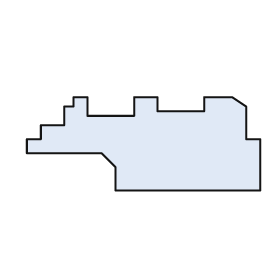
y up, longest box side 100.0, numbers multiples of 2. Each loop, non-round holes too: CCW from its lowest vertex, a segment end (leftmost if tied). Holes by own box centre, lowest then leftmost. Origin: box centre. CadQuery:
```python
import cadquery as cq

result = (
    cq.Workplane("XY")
    .moveTo(-12.0, -20.0)
    .lineTo(50.0, -20.0)
    .lineTo(50.0, 2.0)
    .lineTo(44.0, 2.0)
    .lineTo(44.0, 16.0)
    .lineTo(38.0, 20.0)
    .lineTo(26.0, 20.0)
    .lineTo(26.0, 14.0)
    .lineTo(6.0, 14.0)
    .lineTo(6.0, 20.0)
    .lineTo(-4.0, 20.0)
    .lineTo(-4.0, 12.0)
    .lineTo(-24.0, 12.0)
    .lineTo(-24.0, 20.0)
    .lineTo(-30.0, 20.0)
    .lineTo(-30.0, 16.0)
    .lineTo(-34.0, 16.0)
    .lineTo(-34.0, 8.0)
    .lineTo(-44.0, 8.0)
    .lineTo(-44.0, 2.0)
    .lineTo(-50.0, 2.0)
    .lineTo(-50.0, -4.0)
    .lineTo(-18.0, -4.0)
    .lineTo(-12.0, -10.0)
    .close()
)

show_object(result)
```